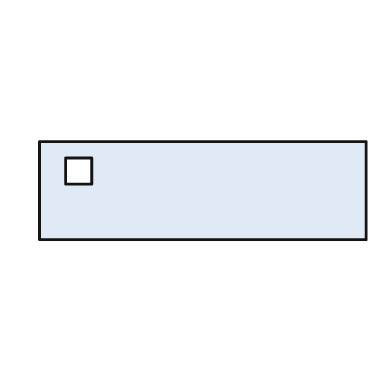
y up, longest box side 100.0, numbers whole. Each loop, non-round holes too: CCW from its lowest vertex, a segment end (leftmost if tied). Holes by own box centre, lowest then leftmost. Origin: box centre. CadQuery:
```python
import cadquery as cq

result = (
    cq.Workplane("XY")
    .moveTo(-50.0, -15.0)
    .lineTo(50.0, -15.0)
    .lineTo(50.0, 15.0)
    .lineTo(-50.0, 15.0)
    .close()
    .moveTo(-42.0, 2.0)
    .lineTo(-34.0, 2.0)
    .lineTo(-34.0, 10.0)
    .lineTo(-42.0, 10.0)
    .close()
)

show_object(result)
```